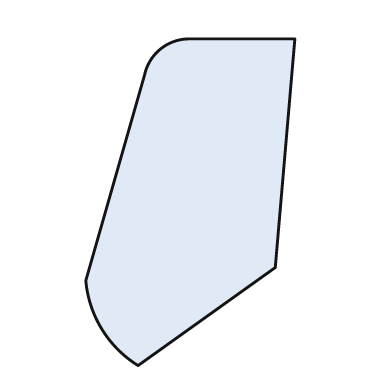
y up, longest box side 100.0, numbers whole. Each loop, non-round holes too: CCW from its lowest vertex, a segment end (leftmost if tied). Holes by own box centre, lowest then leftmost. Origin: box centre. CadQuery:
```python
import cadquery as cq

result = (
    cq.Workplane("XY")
    .moveTo(-16.0, -50.0)
    .lineTo(26.0, -20.0)
    .lineTo(32.0, 50.0)
    .lineTo(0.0, 50.0)
    .threePointArc((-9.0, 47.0), (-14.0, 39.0))
    .lineTo(-32.0, -24.0)
    .threePointArc((-27.0, -39.0), (-16.0, -50.0))
    .close()
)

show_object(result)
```